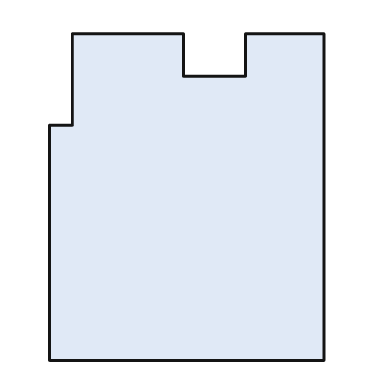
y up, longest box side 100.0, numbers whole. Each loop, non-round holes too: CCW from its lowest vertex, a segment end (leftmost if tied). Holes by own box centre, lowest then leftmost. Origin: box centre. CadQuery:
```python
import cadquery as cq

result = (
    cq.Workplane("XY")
    .moveTo(-42.0, -50.0)
    .lineTo(42.0, -50.0)
    .lineTo(42.0, 50.0)
    .lineTo(18.0, 50.0)
    .lineTo(18.0, 37.0)
    .lineTo(-1.0, 37.0)
    .lineTo(-1.0, 50.0)
    .lineTo(-35.0, 50.0)
    .lineTo(-35.0, 22.0)
    .lineTo(-42.0, 22.0)
    .close()
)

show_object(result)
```